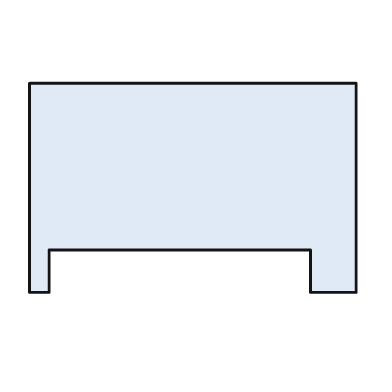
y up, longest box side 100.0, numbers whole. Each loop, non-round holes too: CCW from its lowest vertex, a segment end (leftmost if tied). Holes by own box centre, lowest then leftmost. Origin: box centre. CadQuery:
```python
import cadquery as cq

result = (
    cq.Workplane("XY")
    .moveTo(-50.0, -32.0)
    .lineTo(-44.0, -32.0)
    .lineTo(-44.0, -19.0)
    .lineTo(36.0, -19.0)
    .lineTo(36.0, -32.0)
    .lineTo(50.0, -32.0)
    .lineTo(50.0, 32.0)
    .lineTo(-50.0, 32.0)
    .close()
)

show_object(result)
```